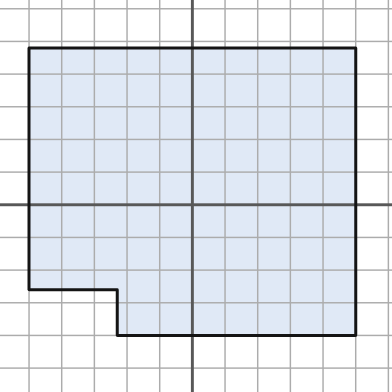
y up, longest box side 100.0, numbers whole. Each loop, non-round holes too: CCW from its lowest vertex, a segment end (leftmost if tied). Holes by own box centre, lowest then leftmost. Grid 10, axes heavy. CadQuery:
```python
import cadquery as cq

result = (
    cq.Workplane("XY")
    .moveTo(-23.0, -40.0)
    .lineTo(50.0, -40.0)
    .lineTo(50.0, 48.0)
    .lineTo(-50.0, 48.0)
    .lineTo(-50.0, -26.0)
    .lineTo(-23.0, -26.0)
    .close()
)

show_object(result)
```